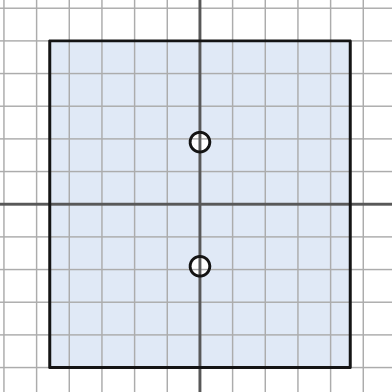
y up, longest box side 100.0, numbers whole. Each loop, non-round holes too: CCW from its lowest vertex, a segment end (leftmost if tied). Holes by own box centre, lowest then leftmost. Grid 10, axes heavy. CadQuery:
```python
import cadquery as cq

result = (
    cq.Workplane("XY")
    .moveTo(-46.0, -50.0)
    .lineTo(46.0, -50.0)
    .lineTo(46.0, 50.0)
    .lineTo(-46.0, 50.0)
    .close()
    .moveTo(0.0, -19.0)
    .circle(3.0)
    .moveTo(0.0, 19.0)
    .circle(3.0)
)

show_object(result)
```